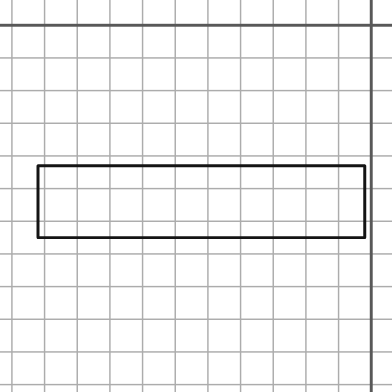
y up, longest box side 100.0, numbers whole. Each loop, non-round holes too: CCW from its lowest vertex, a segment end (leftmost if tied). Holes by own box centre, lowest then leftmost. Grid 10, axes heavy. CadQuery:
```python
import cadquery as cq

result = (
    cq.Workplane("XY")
    .moveTo(-102.0, -65.0)
    .lineTo(-2.0, -65.0)
    .lineTo(-2.0, -43.0)
    .lineTo(-102.0, -43.0)
    .close()
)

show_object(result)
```